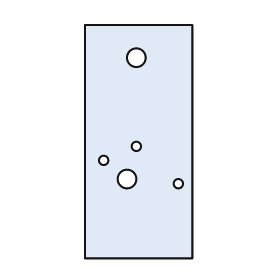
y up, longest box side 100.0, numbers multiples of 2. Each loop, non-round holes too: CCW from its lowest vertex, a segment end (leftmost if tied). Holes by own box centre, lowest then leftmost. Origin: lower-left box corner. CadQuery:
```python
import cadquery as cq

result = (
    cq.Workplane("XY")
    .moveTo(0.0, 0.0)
    .lineTo(46.0, 0.0)
    .lineTo(46.0, 100.0)
    .lineTo(0.0, 100.0)
    .close()
    .moveTo(40.0, 32.0)
    .circle(2.0)
    .moveTo(18.0, 34.0)
    .circle(4.0)
    .moveTo(8.0, 42.0)
    .circle(2.0)
    .moveTo(22.0, 48.0)
    .circle(2.0)
    .moveTo(22.0, 86.0)
    .circle(4.0)
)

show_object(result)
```